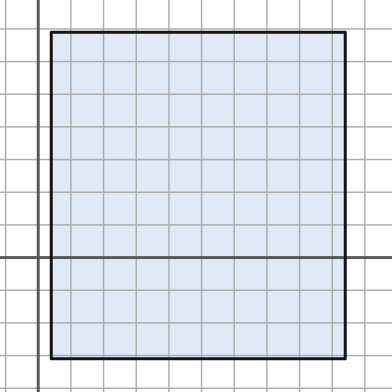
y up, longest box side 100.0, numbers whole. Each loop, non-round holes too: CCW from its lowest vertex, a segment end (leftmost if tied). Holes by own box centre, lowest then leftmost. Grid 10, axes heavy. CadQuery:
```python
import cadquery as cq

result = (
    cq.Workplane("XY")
    .moveTo(4.0, -31.0)
    .lineTo(94.0, -31.0)
    .lineTo(94.0, 69.0)
    .lineTo(4.0, 69.0)
    .close()
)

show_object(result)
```